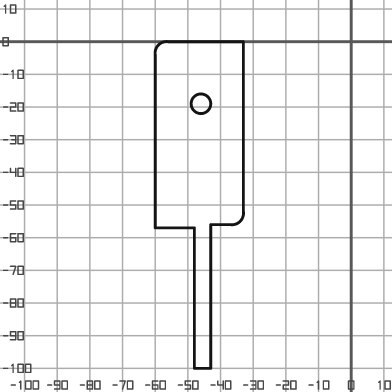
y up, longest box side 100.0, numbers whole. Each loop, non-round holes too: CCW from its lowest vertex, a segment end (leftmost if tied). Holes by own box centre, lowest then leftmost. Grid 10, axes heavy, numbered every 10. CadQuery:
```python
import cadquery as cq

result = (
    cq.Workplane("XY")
    .moveTo(-48.0, -100.0)
    .lineTo(-43.0, -100.0)
    .lineTo(-43.0, -56.0)
    .lineTo(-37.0, -56.0)
    .threePointArc((-34.0, -55.0), (-33.0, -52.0))
    .lineTo(-33.0, 0.0)
    .lineTo(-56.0, 0.0)
    .threePointArc((-59.0, -1.0), (-60.0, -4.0))
    .lineTo(-60.0, -57.0)
    .lineTo(-48.0, -57.0)
    .close()
    .moveTo(-46.0, -19.0)
    .circle(3.0)
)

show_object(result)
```